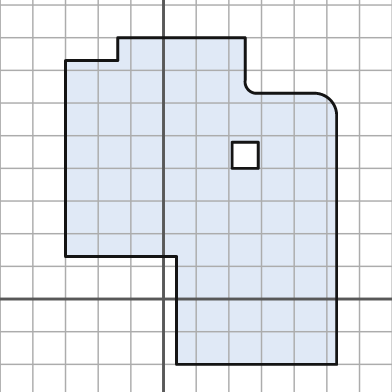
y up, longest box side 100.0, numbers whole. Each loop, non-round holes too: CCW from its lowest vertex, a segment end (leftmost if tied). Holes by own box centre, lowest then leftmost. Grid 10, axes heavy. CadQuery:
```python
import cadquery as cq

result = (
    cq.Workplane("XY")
    .moveTo(4.0, -20.0)
    .lineTo(53.0, -20.0)
    .lineTo(53.0, 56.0)
    .threePointArc((51.0, 61.0), (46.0, 63.0))
    .lineTo(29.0, 63.0)
    .threePointArc((26.0, 64.0), (25.0, 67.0))
    .lineTo(25.0, 80.0)
    .lineTo(-14.0, 80.0)
    .lineTo(-14.0, 73.0)
    .lineTo(-30.0, 73.0)
    .lineTo(-30.0, 13.0)
    .lineTo(4.0, 13.0)
    .close()
    .moveTo(21.0, 40.0)
    .lineTo(29.0, 40.0)
    .lineTo(29.0, 48.0)
    .lineTo(21.0, 48.0)
    .close()
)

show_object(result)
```